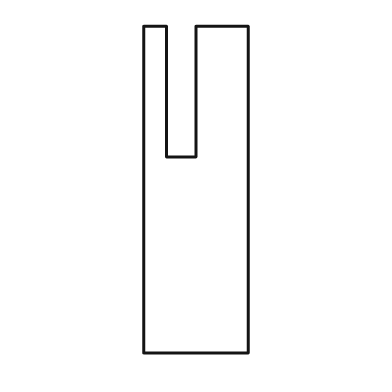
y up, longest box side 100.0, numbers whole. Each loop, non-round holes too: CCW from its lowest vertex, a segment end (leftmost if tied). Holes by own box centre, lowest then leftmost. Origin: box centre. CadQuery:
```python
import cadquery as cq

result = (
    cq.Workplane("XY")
    .moveTo(-16.0, -50.0)
    .lineTo(16.0, -50.0)
    .lineTo(16.0, 50.0)
    .lineTo(0.0, 50.0)
    .lineTo(0.0, 10.0)
    .lineTo(-9.0, 10.0)
    .lineTo(-9.0, 50.0)
    .lineTo(-16.0, 50.0)
    .close()
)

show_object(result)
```